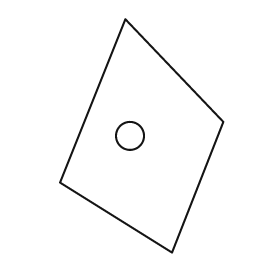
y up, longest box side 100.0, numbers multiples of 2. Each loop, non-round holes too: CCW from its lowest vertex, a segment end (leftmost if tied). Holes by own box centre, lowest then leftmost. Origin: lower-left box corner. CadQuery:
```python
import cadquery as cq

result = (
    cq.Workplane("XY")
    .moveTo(48.0, 0.0)
    .lineTo(70.0, 56.0)
    .lineTo(28.0, 100.0)
    .lineTo(0.0, 30.0)
    .close()
    .moveTo(30.0, 50.0)
    .circle(6.0)
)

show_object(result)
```